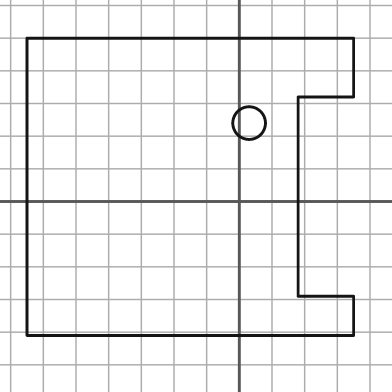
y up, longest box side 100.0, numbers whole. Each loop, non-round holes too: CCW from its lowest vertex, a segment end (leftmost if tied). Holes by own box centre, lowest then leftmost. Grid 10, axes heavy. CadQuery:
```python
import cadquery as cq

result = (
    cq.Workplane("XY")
    .moveTo(-65.0, -41.0)
    .lineTo(35.0, -41.0)
    .lineTo(35.0, -29.0)
    .lineTo(18.0, -29.0)
    .lineTo(18.0, 32.0)
    .lineTo(35.0, 32.0)
    .lineTo(35.0, 50.0)
    .lineTo(-65.0, 50.0)
    .close()
    .moveTo(3.0, 24.0)
    .circle(5.0)
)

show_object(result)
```